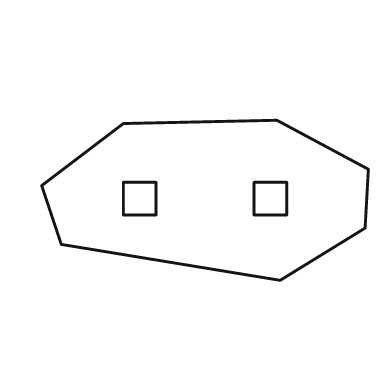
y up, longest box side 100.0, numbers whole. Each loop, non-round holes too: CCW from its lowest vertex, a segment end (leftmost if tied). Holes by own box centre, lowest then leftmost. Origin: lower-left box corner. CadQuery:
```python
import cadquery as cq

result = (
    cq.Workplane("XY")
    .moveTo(73.0, 0.0)
    .lineTo(99.0, 16.0)
    .lineTo(100.0, 34.0)
    .lineTo(72.0, 49.0)
    .lineTo(25.0, 48.0)
    .lineTo(0.0, 29.0)
    .lineTo(6.0, 11.0)
    .close()
    .moveTo(25.0, 20.0)
    .lineTo(35.0, 20.0)
    .lineTo(35.0, 30.0)
    .lineTo(25.0, 30.0)
    .close()
    .moveTo(65.0, 20.0)
    .lineTo(75.0, 20.0)
    .lineTo(75.0, 30.0)
    .lineTo(65.0, 30.0)
    .close()
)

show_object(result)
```